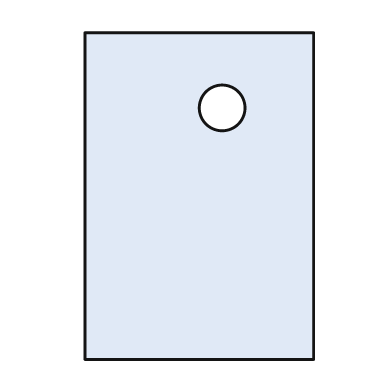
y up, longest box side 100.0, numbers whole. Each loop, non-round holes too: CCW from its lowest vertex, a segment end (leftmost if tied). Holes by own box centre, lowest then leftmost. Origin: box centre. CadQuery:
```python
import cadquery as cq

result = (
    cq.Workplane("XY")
    .moveTo(-35.0, -50.0)
    .lineTo(35.0, -50.0)
    .lineTo(35.0, 50.0)
    .lineTo(-35.0, 50.0)
    .close()
    .moveTo(7.0, 27.0)
    .circle(7.0)
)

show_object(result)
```